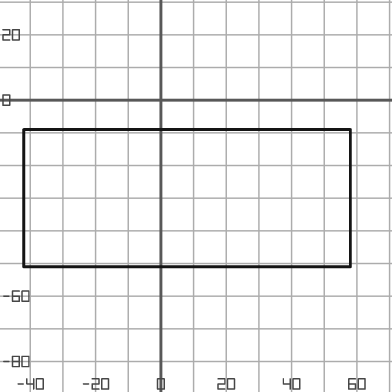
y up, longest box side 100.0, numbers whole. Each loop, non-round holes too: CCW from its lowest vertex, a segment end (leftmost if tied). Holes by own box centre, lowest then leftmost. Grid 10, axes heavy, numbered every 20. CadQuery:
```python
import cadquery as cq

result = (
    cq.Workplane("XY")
    .moveTo(-42.0, -51.0)
    .lineTo(58.0, -51.0)
    .lineTo(58.0, -9.0)
    .lineTo(-42.0, -9.0)
    .close()
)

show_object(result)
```